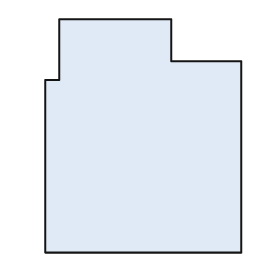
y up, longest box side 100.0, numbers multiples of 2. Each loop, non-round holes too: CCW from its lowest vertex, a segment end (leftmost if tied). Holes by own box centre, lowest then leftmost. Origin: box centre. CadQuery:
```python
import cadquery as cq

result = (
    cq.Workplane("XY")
    .moveTo(-42.0, -50.0)
    .lineTo(42.0, -50.0)
    .lineTo(42.0, 32.0)
    .lineTo(12.0, 32.0)
    .lineTo(12.0, 50.0)
    .lineTo(-36.0, 50.0)
    .lineTo(-36.0, 24.0)
    .lineTo(-42.0, 24.0)
    .close()
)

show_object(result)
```